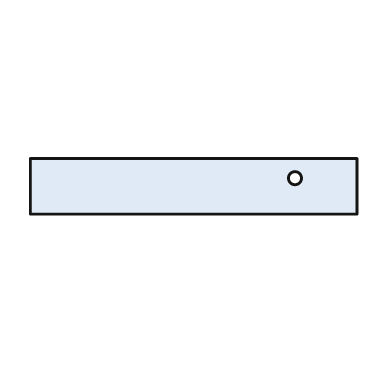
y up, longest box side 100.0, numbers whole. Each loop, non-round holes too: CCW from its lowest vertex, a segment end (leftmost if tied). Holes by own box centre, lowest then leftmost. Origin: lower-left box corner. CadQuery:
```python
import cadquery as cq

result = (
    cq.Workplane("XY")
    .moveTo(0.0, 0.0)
    .lineTo(100.0, 0.0)
    .lineTo(100.0, 17.0)
    .lineTo(0.0, 17.0)
    .close()
    .moveTo(81.0, 11.0)
    .circle(2.0)
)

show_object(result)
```